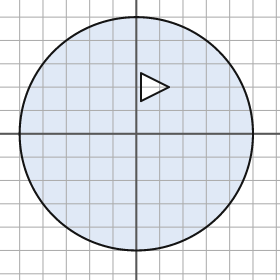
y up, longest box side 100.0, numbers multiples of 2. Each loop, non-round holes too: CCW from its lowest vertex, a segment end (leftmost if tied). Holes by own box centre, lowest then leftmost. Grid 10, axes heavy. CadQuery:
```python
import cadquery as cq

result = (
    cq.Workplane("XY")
    .moveTo(0.0, 0.0)
    .circle(50.0)
    .moveTo(2.0, 14.0)
    .lineTo(14.0, 20.0)
    .lineTo(2.0, 26.0)
    .close()
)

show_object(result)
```